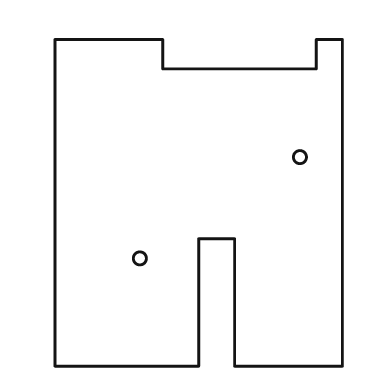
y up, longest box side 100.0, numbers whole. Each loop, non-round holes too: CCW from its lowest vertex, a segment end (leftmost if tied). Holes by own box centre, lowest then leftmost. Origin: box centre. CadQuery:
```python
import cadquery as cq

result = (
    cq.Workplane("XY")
    .moveTo(-44.0, -50.0)
    .lineTo(0.0, -50.0)
    .lineTo(0.0, -11.0)
    .lineTo(11.0, -11.0)
    .lineTo(11.0, -50.0)
    .lineTo(44.0, -50.0)
    .lineTo(44.0, 50.0)
    .lineTo(36.0, 50.0)
    .lineTo(36.0, 41.0)
    .lineTo(-11.0, 41.0)
    .lineTo(-11.0, 50.0)
    .lineTo(-44.0, 50.0)
    .close()
    .moveTo(-18.0, -17.0)
    .circle(2.0)
    .moveTo(31.0, 14.0)
    .circle(2.0)
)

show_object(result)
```